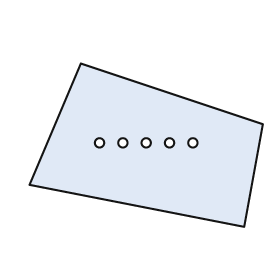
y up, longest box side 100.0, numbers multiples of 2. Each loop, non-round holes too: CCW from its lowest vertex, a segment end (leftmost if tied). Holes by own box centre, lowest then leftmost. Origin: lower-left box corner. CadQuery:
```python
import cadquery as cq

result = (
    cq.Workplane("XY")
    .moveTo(92.0, 0.0)
    .lineTo(100.0, 44.0)
    .lineTo(22.0, 70.0)
    .lineTo(0.0, 18.0)
    .close()
    .moveTo(30.0, 36.0)
    .circle(2.0)
    .moveTo(40.0, 36.0)
    .circle(2.0)
    .moveTo(50.0, 36.0)
    .circle(2.0)
    .moveTo(60.0, 36.0)
    .circle(2.0)
    .moveTo(70.0, 36.0)
    .circle(2.0)
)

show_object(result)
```